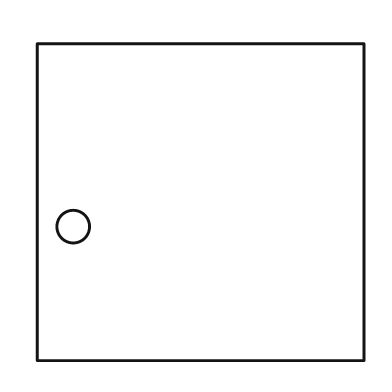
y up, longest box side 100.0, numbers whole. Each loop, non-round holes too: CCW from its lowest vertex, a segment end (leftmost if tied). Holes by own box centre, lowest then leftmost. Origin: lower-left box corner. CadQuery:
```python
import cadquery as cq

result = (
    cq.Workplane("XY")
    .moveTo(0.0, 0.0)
    .lineTo(100.0, 0.0)
    .lineTo(100.0, 97.0)
    .lineTo(0.0, 97.0)
    .close()
    .moveTo(11.0, 41.0)
    .circle(5.0)
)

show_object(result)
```